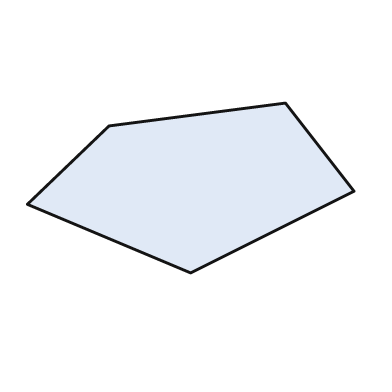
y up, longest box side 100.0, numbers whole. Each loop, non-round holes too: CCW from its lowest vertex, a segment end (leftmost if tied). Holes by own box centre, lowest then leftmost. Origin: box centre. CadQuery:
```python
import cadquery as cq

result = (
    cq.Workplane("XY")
    .moveTo(0.0, -26.0)
    .lineTo(50.0, -1.0)
    .lineTo(29.0, 26.0)
    .lineTo(-25.0, 19.0)
    .lineTo(-50.0, -5.0)
    .close()
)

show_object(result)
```